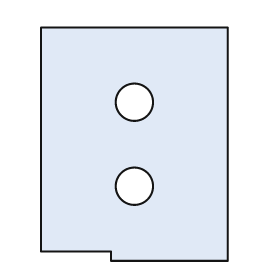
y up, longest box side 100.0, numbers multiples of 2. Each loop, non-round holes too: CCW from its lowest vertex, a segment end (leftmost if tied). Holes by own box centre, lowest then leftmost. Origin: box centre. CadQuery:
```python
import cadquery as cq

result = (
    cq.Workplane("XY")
    .moveTo(-10.0, -50.0)
    .lineTo(40.0, -50.0)
    .lineTo(40.0, 50.0)
    .lineTo(-40.0, 50.0)
    .lineTo(-40.0, -46.0)
    .lineTo(-10.0, -46.0)
    .close()
    .moveTo(0.0, -18.0)
    .circle(8.0)
    .moveTo(0.0, 18.0)
    .circle(8.0)
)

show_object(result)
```